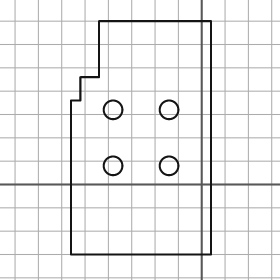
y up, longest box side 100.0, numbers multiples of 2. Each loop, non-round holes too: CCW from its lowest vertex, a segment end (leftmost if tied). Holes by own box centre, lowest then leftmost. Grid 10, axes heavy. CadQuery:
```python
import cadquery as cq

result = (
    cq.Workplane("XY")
    .moveTo(-56.0, -30.0)
    .lineTo(4.0, -30.0)
    .lineTo(4.0, 70.0)
    .lineTo(-44.0, 70.0)
    .lineTo(-44.0, 46.0)
    .lineTo(-52.0, 46.0)
    .lineTo(-52.0, 36.0)
    .lineTo(-56.0, 36.0)
    .close()
    .moveTo(-38.0, 8.0)
    .circle(4.0)
    .moveTo(-14.0, 8.0)
    .circle(4.0)
    .moveTo(-38.0, 32.0)
    .circle(4.0)
    .moveTo(-14.0, 32.0)
    .circle(4.0)
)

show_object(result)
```